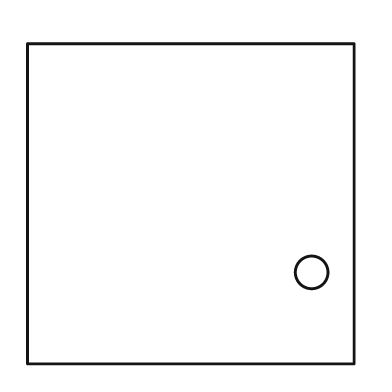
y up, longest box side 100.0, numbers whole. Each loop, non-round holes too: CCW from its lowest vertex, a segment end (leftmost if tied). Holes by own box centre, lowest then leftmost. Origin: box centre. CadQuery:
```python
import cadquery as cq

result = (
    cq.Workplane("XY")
    .moveTo(-50.0, -49.0)
    .lineTo(50.0, -49.0)
    .lineTo(50.0, 49.0)
    .lineTo(-50.0, 49.0)
    .close()
    .moveTo(37.0, -21.0)
    .circle(5.0)
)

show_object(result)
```